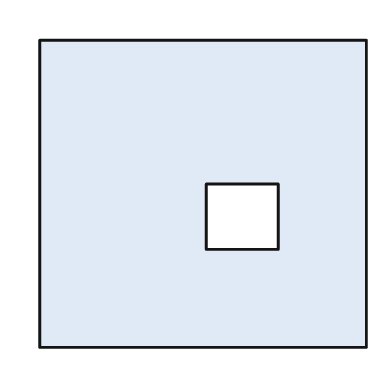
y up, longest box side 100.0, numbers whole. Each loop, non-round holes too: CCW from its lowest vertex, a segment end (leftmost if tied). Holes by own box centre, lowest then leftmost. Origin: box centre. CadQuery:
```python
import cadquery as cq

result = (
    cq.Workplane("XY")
    .moveTo(-50.0, -47.0)
    .lineTo(50.0, -47.0)
    .lineTo(50.0, 47.0)
    .lineTo(-50.0, 47.0)
    .close()
    .moveTo(1.0, -17.0)
    .lineTo(23.0, -17.0)
    .lineTo(23.0, 3.0)
    .lineTo(1.0, 3.0)
    .close()
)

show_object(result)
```